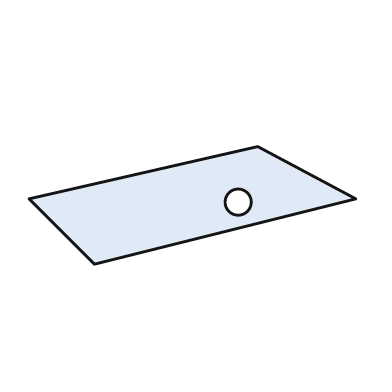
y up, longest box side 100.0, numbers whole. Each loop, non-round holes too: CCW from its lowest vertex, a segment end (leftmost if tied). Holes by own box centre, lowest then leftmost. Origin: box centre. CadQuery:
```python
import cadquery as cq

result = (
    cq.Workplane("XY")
    .moveTo(-30.0, -18.0)
    .lineTo(50.0, 2.0)
    .lineTo(20.0, 18.0)
    .lineTo(-50.0, 2.0)
    .close()
    .moveTo(14.0, 1.0)
    .circle(4.0)
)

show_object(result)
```